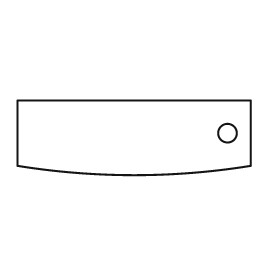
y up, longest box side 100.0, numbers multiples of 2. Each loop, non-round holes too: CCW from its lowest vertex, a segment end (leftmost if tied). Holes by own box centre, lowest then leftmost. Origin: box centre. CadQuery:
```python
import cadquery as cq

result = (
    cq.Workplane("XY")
    .moveTo(-50.0, -12.0)
    .threePointArc((0.0, -16.0), (50.0, -12.0))
    .lineTo(50.0, 16.0)
    .lineTo(-50.0, 16.0)
    .close()
    .moveTo(40.0, 2.0)
    .circle(4.0)
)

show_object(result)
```